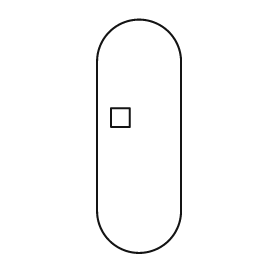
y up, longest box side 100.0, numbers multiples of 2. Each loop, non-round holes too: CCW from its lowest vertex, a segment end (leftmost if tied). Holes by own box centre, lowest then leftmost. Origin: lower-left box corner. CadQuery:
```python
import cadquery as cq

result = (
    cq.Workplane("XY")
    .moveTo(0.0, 18.0)
    .threePointArc((18.0, 0.0), (36.0, 18.0))
    .lineTo(36.0, 82.0)
    .threePointArc((18.0, 100.0), (0.0, 82.0))
    .close()
    .moveTo(6.0, 54.0)
    .lineTo(14.0, 54.0)
    .lineTo(14.0, 62.0)
    .lineTo(6.0, 62.0)
    .close()
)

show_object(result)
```